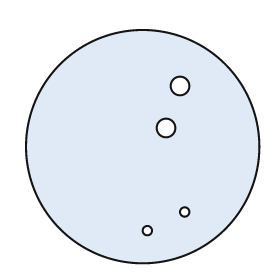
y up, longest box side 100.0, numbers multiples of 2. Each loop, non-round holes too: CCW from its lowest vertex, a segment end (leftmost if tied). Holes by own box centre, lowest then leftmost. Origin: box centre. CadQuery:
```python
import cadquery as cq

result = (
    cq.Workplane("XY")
    .moveTo(0.0, 0.0)
    .circle(50.0)
    .moveTo(2.0, -36.0)
    .circle(2.0)
    .moveTo(18.0, -28.0)
    .circle(2.0)
    .moveTo(10.0, 8.0)
    .circle(4.0)
    .moveTo(16.0, 26.0)
    .circle(4.0)
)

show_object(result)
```